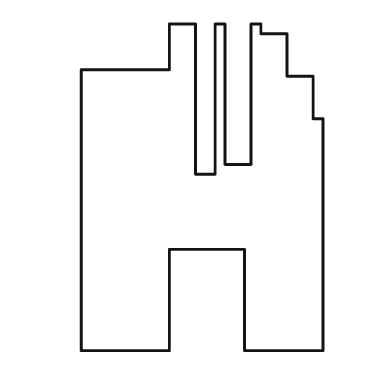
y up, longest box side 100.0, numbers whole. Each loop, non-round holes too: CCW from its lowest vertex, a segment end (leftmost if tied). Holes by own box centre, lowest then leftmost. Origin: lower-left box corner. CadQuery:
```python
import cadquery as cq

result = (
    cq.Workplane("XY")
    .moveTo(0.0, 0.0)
    .lineTo(27.0, 0.0)
    .lineTo(27.0, 31.0)
    .lineTo(50.0, 31.0)
    .lineTo(50.0, 0.0)
    .lineTo(74.0, 0.0)
    .lineTo(74.0, 71.0)
    .lineTo(71.0, 71.0)
    .lineTo(71.0, 84.0)
    .lineTo(63.0, 84.0)
    .lineTo(63.0, 97.0)
    .lineTo(55.0, 97.0)
    .lineTo(55.0, 100.0)
    .lineTo(52.0, 100.0)
    .lineTo(52.0, 57.0)
    .lineTo(44.0, 57.0)
    .lineTo(44.0, 100.0)
    .lineTo(41.0, 100.0)
    .lineTo(41.0, 54.0)
    .lineTo(35.0, 54.0)
    .lineTo(35.0, 100.0)
    .lineTo(27.0, 100.0)
    .lineTo(27.0, 86.0)
    .lineTo(0.0, 86.0)
    .close()
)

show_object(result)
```